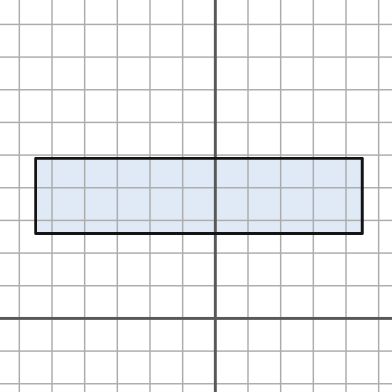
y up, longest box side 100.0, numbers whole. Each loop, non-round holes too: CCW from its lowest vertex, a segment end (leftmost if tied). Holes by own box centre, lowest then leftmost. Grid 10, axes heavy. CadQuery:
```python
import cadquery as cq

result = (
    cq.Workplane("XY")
    .moveTo(-55.0, 26.0)
    .lineTo(45.0, 26.0)
    .lineTo(45.0, 49.0)
    .lineTo(-55.0, 49.0)
    .close()
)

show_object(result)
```